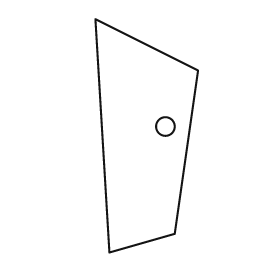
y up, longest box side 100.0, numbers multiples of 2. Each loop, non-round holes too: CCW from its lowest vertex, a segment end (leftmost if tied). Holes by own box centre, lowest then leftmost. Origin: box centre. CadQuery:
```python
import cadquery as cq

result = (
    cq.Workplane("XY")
    .moveTo(-16.0, -50.0)
    .lineTo(12.0, -42.0)
    .lineTo(22.0, 28.0)
    .lineTo(-22.0, 50.0)
    .close()
    .moveTo(8.0, 4.0)
    .circle(4.0)
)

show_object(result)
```